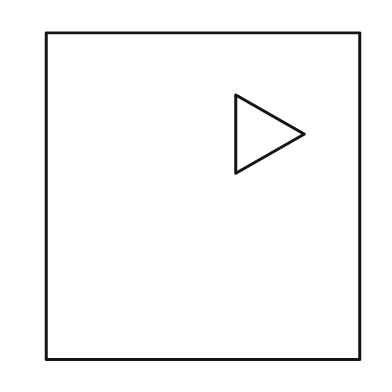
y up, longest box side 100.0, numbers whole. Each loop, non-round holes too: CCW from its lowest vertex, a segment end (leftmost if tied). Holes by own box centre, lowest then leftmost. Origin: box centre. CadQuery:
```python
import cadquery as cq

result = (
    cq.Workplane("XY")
    .moveTo(-48.0, -50.0)
    .lineTo(48.0, -50.0)
    .lineTo(48.0, 50.0)
    .lineTo(-48.0, 50.0)
    .close()
    .moveTo(10.0, 7.0)
    .lineTo(31.0, 19.0)
    .lineTo(10.0, 31.0)
    .close()
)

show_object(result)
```